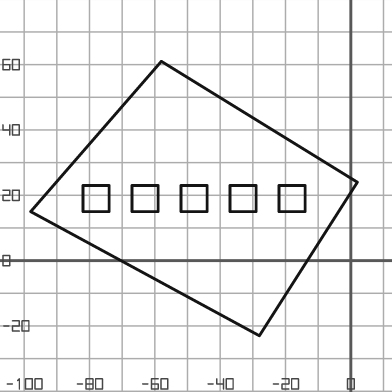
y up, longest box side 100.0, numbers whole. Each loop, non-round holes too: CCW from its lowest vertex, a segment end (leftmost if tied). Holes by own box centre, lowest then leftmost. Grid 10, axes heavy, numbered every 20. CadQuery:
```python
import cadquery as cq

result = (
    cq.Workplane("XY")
    .moveTo(-28.0, -23.0)
    .lineTo(2.0, 24.0)
    .lineTo(-58.0, 61.0)
    .lineTo(-98.0, 15.0)
    .close()
    .moveTo(-82.0, 15.0)
    .lineTo(-74.0, 15.0)
    .lineTo(-74.0, 23.0)
    .lineTo(-82.0, 23.0)
    .close()
    .moveTo(-67.0, 15.0)
    .lineTo(-59.0, 15.0)
    .lineTo(-59.0, 23.0)
    .lineTo(-67.0, 23.0)
    .close()
    .moveTo(-52.0, 15.0)
    .lineTo(-44.0, 15.0)
    .lineTo(-44.0, 23.0)
    .lineTo(-52.0, 23.0)
    .close()
    .moveTo(-37.0, 15.0)
    .lineTo(-29.0, 15.0)
    .lineTo(-29.0, 23.0)
    .lineTo(-37.0, 23.0)
    .close()
    .moveTo(-22.0, 15.0)
    .lineTo(-14.0, 15.0)
    .lineTo(-14.0, 23.0)
    .lineTo(-22.0, 23.0)
    .close()
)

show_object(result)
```